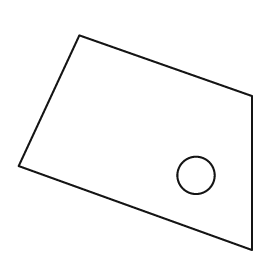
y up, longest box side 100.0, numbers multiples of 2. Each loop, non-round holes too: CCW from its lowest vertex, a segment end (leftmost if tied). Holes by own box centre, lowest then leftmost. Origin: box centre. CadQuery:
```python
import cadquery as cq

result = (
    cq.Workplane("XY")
    .moveTo(50.0, -46.0)
    .lineTo(50.0, 20.0)
    .lineTo(-24.0, 46.0)
    .lineTo(-50.0, -10.0)
    .close()
    .moveTo(26.0, -14.0)
    .circle(8.0)
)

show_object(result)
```